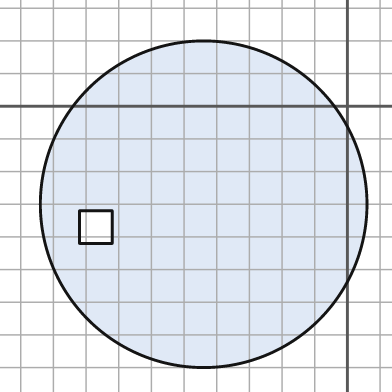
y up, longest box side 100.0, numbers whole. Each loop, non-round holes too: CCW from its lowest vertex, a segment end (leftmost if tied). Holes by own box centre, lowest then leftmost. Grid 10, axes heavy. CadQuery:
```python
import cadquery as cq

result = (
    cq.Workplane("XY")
    .moveTo(-44.0, -30.0)
    .circle(50.0)
    .moveTo(-82.0, -42.0)
    .lineTo(-72.0, -42.0)
    .lineTo(-72.0, -32.0)
    .lineTo(-82.0, -32.0)
    .close()
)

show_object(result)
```